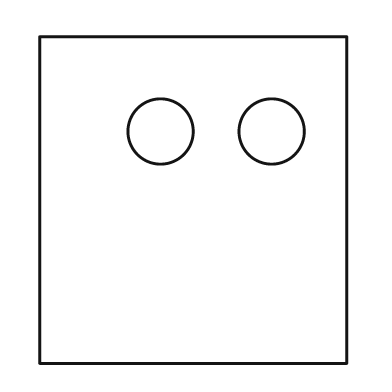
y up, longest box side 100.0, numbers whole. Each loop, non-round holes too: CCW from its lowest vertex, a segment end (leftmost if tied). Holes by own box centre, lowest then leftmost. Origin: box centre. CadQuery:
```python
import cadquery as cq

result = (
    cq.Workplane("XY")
    .moveTo(-47.0, -50.0)
    .lineTo(47.0, -50.0)
    .lineTo(47.0, 50.0)
    .lineTo(-47.0, 50.0)
    .close()
    .moveTo(-10.0, 21.0)
    .circle(10.0)
    .moveTo(24.0, 21.0)
    .circle(10.0)
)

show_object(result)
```